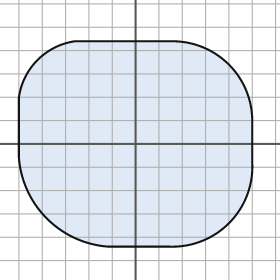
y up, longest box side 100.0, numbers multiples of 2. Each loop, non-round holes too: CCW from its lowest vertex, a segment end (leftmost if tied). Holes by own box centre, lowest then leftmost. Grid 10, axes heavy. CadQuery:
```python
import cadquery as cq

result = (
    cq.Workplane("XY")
    .moveTo(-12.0, -44.0)
    .lineTo(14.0, -44.0)
    .threePointArc((40.0, -34.0), (50.0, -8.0))
    .lineTo(50.0, 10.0)
    .threePointArc((40.0, 34.0), (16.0, 44.0))
    .lineTo(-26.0, 44.0)
    .threePointArc((-42.0, 36.0), (-50.0, 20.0))
    .lineTo(-50.0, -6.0)
    .threePointArc((-38.0, -32.0), (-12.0, -44.0))
    .close()
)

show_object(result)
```